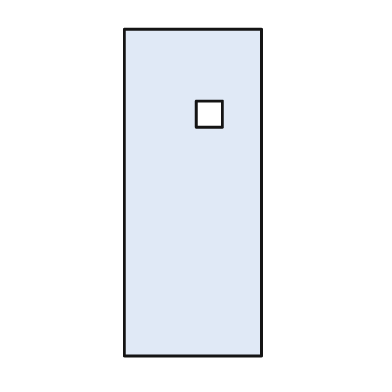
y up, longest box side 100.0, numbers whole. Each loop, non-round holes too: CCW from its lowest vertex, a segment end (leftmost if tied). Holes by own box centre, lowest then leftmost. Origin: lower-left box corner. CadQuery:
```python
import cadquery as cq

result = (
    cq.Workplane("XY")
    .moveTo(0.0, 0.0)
    .lineTo(42.0, 0.0)
    .lineTo(42.0, 100.0)
    .lineTo(0.0, 100.0)
    .close()
    .moveTo(22.0, 70.0)
    .lineTo(30.0, 70.0)
    .lineTo(30.0, 78.0)
    .lineTo(22.0, 78.0)
    .close()
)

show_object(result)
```